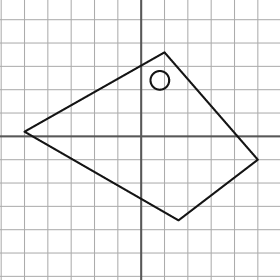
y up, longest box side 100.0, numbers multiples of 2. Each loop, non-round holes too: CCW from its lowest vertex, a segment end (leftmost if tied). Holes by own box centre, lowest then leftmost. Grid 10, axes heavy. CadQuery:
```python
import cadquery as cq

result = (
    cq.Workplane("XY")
    .moveTo(16.0, -36.0)
    .lineTo(50.0, -10.0)
    .lineTo(10.0, 36.0)
    .lineTo(-50.0, 2.0)
    .close()
    .moveTo(8.0, 24.0)
    .circle(4.0)
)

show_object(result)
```